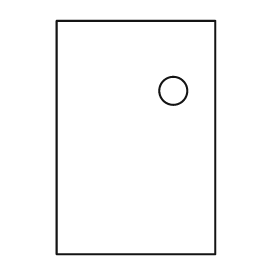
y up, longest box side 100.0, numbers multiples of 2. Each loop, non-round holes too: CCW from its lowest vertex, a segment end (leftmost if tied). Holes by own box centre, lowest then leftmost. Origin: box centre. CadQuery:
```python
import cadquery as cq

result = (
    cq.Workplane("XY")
    .moveTo(-34.0, -50.0)
    .lineTo(34.0, -50.0)
    .lineTo(34.0, 50.0)
    .lineTo(-34.0, 50.0)
    .close()
    .moveTo(16.0, 20.0)
    .circle(6.0)
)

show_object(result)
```